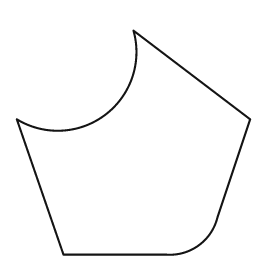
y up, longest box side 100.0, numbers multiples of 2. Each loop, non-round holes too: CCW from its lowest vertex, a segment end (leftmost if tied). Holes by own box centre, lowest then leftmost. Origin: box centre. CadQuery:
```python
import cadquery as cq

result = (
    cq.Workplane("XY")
    .moveTo(-30.0, -48.0)
    .lineTo(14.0, -48.0)
    .threePointArc((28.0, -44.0), (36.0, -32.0))
    .lineTo(50.0, 10.0)
    .lineTo(0.0, 48.0)
    .threePointArc((-12.0, 12.0), (-50.0, 10.0))
    .close()
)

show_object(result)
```